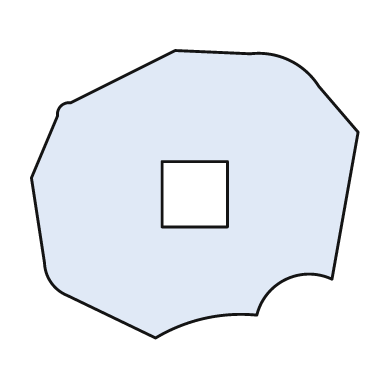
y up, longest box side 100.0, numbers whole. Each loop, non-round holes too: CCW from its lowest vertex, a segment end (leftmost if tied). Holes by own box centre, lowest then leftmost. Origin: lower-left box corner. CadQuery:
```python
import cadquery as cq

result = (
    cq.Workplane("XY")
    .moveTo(38.0, 0.0)
    .threePointArc((53.0, 6.0), (69.0, 7.0))
    .threePointArc((78.0, 18.0), (92.0, 18.0))
    .lineTo(100.0, 63.0)
    .lineTo(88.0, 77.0)
    .threePointArc((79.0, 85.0), (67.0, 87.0))
    .lineTo(44.0, 88.0)
    .lineTo(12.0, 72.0)
    .threePointArc((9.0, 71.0), (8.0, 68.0))
    .lineTo(0.0, 49.0)
    .lineTo(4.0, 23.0)
    .threePointArc((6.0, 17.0), (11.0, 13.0))
    .close()
    .moveTo(40.0, 34.0)
    .lineTo(60.0, 34.0)
    .lineTo(60.0, 54.0)
    .lineTo(40.0, 54.0)
    .close()
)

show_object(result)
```